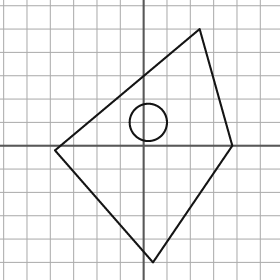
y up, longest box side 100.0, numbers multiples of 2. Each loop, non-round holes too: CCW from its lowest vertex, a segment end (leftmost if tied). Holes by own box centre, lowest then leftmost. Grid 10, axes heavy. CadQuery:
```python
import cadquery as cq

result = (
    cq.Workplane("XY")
    .moveTo(4.0, -50.0)
    .lineTo(38.0, 0.0)
    .lineTo(24.0, 50.0)
    .lineTo(-38.0, -2.0)
    .close()
    .moveTo(2.0, 10.0)
    .circle(8.0)
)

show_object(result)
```